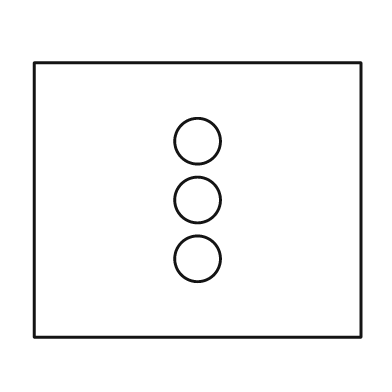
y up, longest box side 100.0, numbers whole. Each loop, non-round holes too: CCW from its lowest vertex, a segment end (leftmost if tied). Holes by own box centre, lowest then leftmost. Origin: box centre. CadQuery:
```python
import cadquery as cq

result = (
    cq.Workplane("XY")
    .moveTo(-50.0, -42.0)
    .lineTo(50.0, -42.0)
    .lineTo(50.0, 42.0)
    .lineTo(-50.0, 42.0)
    .close()
    .moveTo(0.0, -18.0)
    .circle(7.0)
    .moveTo(0.0, 0.0)
    .circle(7.0)
    .moveTo(0.0, 18.0)
    .circle(7.0)
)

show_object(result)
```